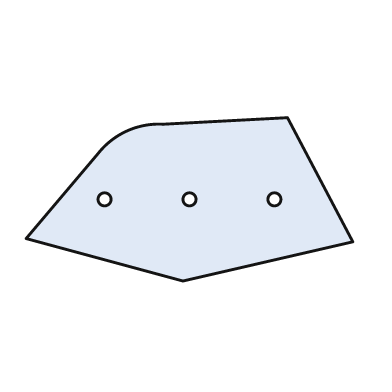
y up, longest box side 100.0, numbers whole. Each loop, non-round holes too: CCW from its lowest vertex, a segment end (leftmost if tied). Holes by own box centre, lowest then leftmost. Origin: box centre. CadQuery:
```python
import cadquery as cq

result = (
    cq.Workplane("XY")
    .moveTo(-2.0, -25.0)
    .lineTo(50.0, -13.0)
    .lineTo(30.0, 25.0)
    .lineTo(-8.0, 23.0)
    .threePointArc((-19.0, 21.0), (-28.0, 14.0))
    .lineTo(-50.0, -12.0)
    .close()
    .moveTo(-26.0, 0.0)
    .circle(2.0)
    .moveTo(0.0, 0.0)
    .circle(2.0)
    .moveTo(26.0, 0.0)
    .circle(2.0)
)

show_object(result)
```